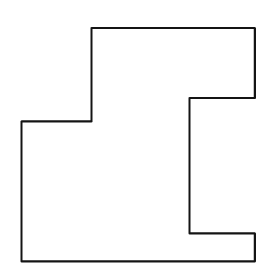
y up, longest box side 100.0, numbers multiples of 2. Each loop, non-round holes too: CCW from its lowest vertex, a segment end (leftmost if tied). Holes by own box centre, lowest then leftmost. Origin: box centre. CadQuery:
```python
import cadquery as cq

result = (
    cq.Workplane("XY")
    .moveTo(-50.0, -50.0)
    .lineTo(50.0, -50.0)
    .lineTo(50.0, -38.0)
    .lineTo(22.0, -38.0)
    .lineTo(22.0, 20.0)
    .lineTo(50.0, 20.0)
    .lineTo(50.0, 50.0)
    .lineTo(-20.0, 50.0)
    .lineTo(-20.0, 10.0)
    .lineTo(-50.0, 10.0)
    .close()
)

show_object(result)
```